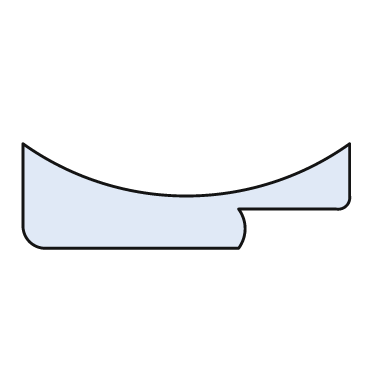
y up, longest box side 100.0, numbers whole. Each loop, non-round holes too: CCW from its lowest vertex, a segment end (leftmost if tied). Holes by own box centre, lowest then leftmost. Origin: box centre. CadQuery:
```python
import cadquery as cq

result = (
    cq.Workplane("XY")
    .moveTo(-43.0, -16.0)
    .lineTo(16.0, -16.0)
    .threePointArc((18.0, -10.0), (16.0, -4.0))
    .lineTo(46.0, -4.0)
    .threePointArc((49.0, -3.0), (50.0, 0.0))
    .lineTo(50.0, 16.0)
    .threePointArc((0.0, 0.0), (-50.0, 16.0))
    .lineTo(-50.0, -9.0)
    .threePointArc((-48.0, -14.0), (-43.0, -16.0))
    .close()
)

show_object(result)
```